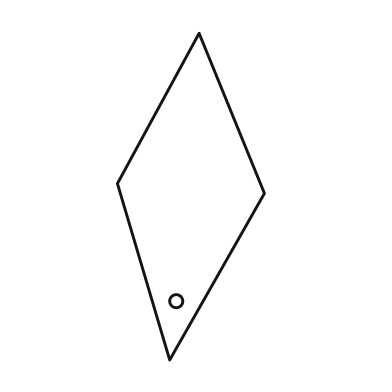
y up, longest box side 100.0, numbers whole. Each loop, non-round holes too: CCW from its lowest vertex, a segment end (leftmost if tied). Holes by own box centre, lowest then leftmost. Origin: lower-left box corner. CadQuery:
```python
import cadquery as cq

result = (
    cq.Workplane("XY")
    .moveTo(16.0, 0.0)
    .lineTo(45.0, 51.0)
    .lineTo(25.0, 100.0)
    .lineTo(0.0, 54.0)
    .close()
    .moveTo(18.0, 18.0)
    .circle(2.0)
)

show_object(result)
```